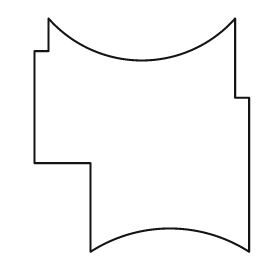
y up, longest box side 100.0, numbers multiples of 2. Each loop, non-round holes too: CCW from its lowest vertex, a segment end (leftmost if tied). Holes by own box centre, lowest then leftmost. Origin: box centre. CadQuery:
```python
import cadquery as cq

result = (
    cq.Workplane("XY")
    .moveTo(-22.0, -50.0)
    .threePointArc((12.0, -40.0), (46.0, -50.0))
    .lineTo(46.0, 16.0)
    .lineTo(40.0, 16.0)
    .lineTo(40.0, 50.0)
    .threePointArc((0.0, 32.0), (-40.0, 50.0))
    .lineTo(-40.0, 36.0)
    .lineTo(-46.0, 36.0)
    .lineTo(-46.0, -12.0)
    .lineTo(-22.0, -12.0)
    .close()
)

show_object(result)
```